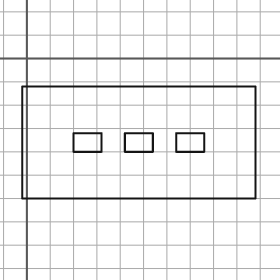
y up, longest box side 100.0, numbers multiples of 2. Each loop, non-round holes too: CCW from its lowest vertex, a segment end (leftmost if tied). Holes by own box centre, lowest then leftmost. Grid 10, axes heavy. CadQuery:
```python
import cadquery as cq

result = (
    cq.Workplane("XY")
    .moveTo(-2.0, -60.0)
    .lineTo(98.0, -60.0)
    .lineTo(98.0, -12.0)
    .lineTo(-2.0, -12.0)
    .close()
    .moveTo(20.0, -40.0)
    .lineTo(32.0, -40.0)
    .lineTo(32.0, -32.0)
    .lineTo(20.0, -32.0)
    .close()
    .moveTo(42.0, -40.0)
    .lineTo(54.0, -40.0)
    .lineTo(54.0, -32.0)
    .lineTo(42.0, -32.0)
    .close()
    .moveTo(64.0, -40.0)
    .lineTo(76.0, -40.0)
    .lineTo(76.0, -32.0)
    .lineTo(64.0, -32.0)
    .close()
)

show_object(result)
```